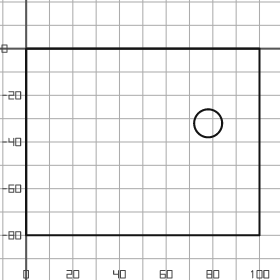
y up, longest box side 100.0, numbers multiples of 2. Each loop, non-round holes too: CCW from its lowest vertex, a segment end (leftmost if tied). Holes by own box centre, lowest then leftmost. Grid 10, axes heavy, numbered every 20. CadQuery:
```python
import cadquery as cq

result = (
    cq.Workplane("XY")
    .moveTo(0.0, -80.0)
    .lineTo(100.0, -80.0)
    .lineTo(100.0, 0.0)
    .lineTo(0.0, 0.0)
    .close()
    .moveTo(78.0, -32.0)
    .circle(6.0)
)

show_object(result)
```